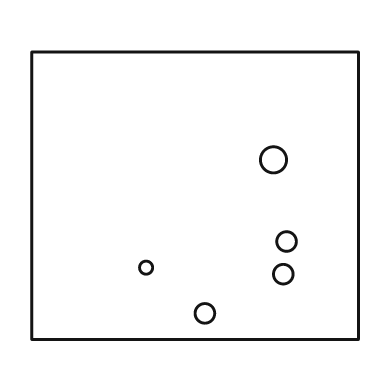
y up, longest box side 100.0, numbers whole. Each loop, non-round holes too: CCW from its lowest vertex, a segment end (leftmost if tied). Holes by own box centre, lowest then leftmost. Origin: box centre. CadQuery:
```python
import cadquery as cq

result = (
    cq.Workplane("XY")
    .moveTo(-50.0, -44.0)
    .lineTo(50.0, -44.0)
    .lineTo(50.0, 44.0)
    .lineTo(-50.0, 44.0)
    .close()
    .moveTo(3.0, -36.0)
    .circle(3.0)
    .moveTo(27.0, -24.0)
    .circle(3.0)
    .moveTo(-15.0, -22.0)
    .circle(2.0)
    .moveTo(28.0, -14.0)
    .circle(3.0)
    .moveTo(24.0, 11.0)
    .circle(4.0)
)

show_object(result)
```